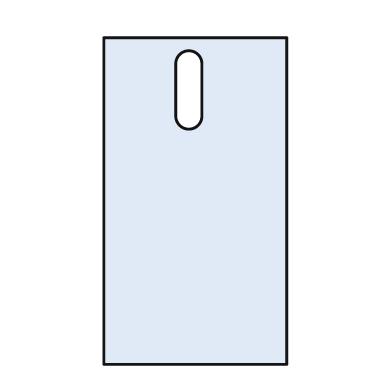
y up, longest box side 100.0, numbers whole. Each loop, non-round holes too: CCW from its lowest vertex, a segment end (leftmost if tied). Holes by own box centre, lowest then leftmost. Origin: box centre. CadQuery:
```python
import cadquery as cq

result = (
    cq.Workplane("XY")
    .moveTo(-28.0, -50.0)
    .lineTo(28.0, -50.0)
    .lineTo(28.0, 50.0)
    .lineTo(-28.0, 50.0)
    .close()
    .moveTo(-6.0, 26.0)
    .threePointArc((-2.0, 22.0), (2.0, 26.0))
    .lineTo(2.0, 42.0)
    .threePointArc((-2.0, 46.0), (-6.0, 42.0))
    .close()
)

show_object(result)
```